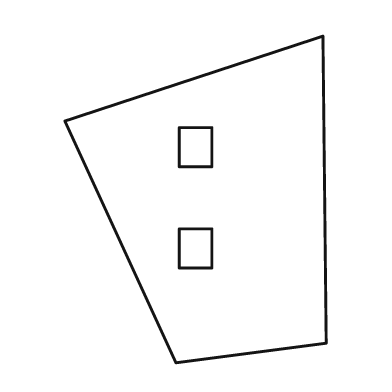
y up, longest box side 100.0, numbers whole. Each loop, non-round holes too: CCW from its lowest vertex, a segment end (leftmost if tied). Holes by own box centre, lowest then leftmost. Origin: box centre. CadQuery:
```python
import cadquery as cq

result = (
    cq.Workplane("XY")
    .moveTo(-6.0, -50.0)
    .lineTo(40.0, -44.0)
    .lineTo(39.0, 50.0)
    .lineTo(-40.0, 24.0)
    .close()
    .moveTo(-5.0, -21.0)
    .lineTo(5.0, -21.0)
    .lineTo(5.0, -9.0)
    .lineTo(-5.0, -9.0)
    .close()
    .moveTo(-5.0, 10.0)
    .lineTo(5.0, 10.0)
    .lineTo(5.0, 22.0)
    .lineTo(-5.0, 22.0)
    .close()
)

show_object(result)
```